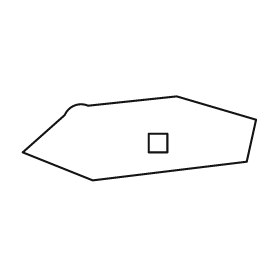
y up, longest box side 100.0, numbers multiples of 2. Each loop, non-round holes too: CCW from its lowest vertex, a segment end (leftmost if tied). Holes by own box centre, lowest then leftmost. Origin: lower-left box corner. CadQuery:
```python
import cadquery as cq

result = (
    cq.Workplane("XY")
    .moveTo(30.0, 0.0)
    .lineTo(96.0, 8.0)
    .lineTo(100.0, 26.0)
    .lineTo(66.0, 36.0)
    .lineTo(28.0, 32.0)
    .threePointArc((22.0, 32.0), (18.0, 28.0))
    .lineTo(0.0, 12.0)
    .close()
    .moveTo(54.0, 12.0)
    .lineTo(62.0, 12.0)
    .lineTo(62.0, 20.0)
    .lineTo(54.0, 20.0)
    .close()
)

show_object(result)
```